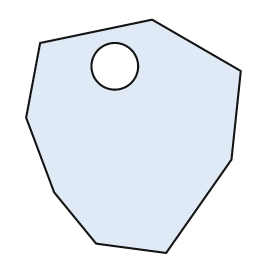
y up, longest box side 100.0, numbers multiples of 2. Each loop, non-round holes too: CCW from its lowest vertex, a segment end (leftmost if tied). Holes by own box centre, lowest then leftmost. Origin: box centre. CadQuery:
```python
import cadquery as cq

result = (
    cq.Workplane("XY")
    .moveTo(14.0, -50.0)
    .lineTo(42.0, -10.0)
    .lineTo(46.0, 28.0)
    .lineTo(8.0, 50.0)
    .lineTo(-40.0, 40.0)
    .lineTo(-46.0, 8.0)
    .lineTo(-34.0, -24.0)
    .lineTo(-16.0, -46.0)
    .close()
    .moveTo(-8.0, 30.0)
    .circle(10.0)
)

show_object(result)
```